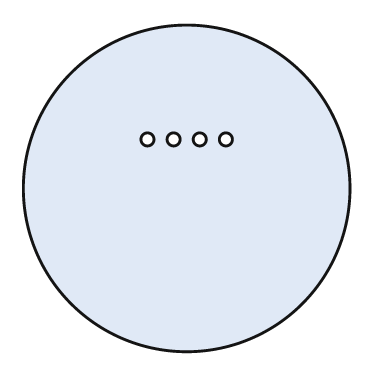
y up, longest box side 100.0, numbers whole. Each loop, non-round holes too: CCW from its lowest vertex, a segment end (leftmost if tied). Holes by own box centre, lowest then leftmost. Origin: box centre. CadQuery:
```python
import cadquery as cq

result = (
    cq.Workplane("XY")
    .moveTo(0.0, 0.0)
    .circle(50.0)
    .moveTo(-12.0, 15.0)
    .circle(2.0)
    .moveTo(-4.0, 15.0)
    .circle(2.0)
    .moveTo(4.0, 15.0)
    .circle(2.0)
    .moveTo(12.0, 15.0)
    .circle(2.0)
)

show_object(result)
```